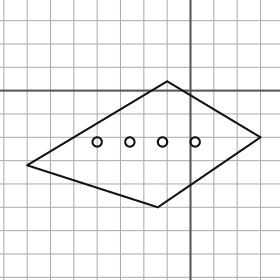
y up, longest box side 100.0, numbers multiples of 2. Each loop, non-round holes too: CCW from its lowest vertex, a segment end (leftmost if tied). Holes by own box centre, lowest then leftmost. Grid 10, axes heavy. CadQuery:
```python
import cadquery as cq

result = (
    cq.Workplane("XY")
    .moveTo(-14.0, -50.0)
    .lineTo(30.0, -20.0)
    .lineTo(-10.0, 4.0)
    .lineTo(-70.0, -32.0)
    .close()
    .moveTo(-40.0, -22.0)
    .circle(2.0)
    .moveTo(-26.0, -22.0)
    .circle(2.0)
    .moveTo(-12.0, -22.0)
    .circle(2.0)
    .moveTo(2.0, -22.0)
    .circle(2.0)
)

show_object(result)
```